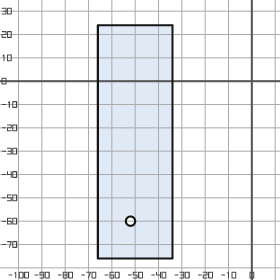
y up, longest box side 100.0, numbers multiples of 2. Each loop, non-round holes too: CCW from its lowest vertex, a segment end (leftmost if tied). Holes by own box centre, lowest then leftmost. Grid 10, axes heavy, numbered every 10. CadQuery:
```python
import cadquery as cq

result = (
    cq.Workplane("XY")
    .moveTo(-66.0, -76.0)
    .lineTo(-34.0, -76.0)
    .lineTo(-34.0, 24.0)
    .lineTo(-66.0, 24.0)
    .close()
    .moveTo(-52.0, -60.0)
    .circle(2.0)
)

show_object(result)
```